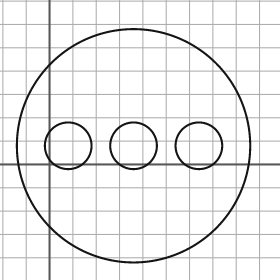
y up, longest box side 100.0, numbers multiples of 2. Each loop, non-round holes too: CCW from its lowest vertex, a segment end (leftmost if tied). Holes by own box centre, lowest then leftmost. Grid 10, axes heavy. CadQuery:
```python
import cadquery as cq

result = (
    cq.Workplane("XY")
    .moveTo(36.0, 8.0)
    .circle(50.0)
    .moveTo(8.0, 8.0)
    .circle(10.0)
    .moveTo(36.0, 8.0)
    .circle(10.0)
    .moveTo(64.0, 8.0)
    .circle(10.0)
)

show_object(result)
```